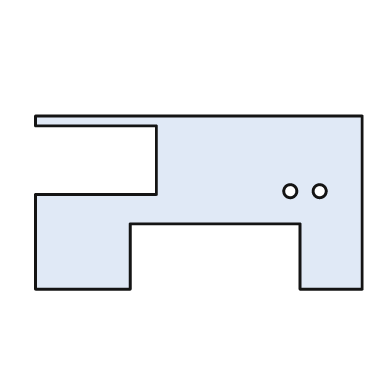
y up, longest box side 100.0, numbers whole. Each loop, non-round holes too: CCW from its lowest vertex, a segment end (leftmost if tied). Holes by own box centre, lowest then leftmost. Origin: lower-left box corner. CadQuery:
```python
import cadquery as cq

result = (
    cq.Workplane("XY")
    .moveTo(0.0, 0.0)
    .lineTo(29.0, 0.0)
    .lineTo(29.0, 20.0)
    .lineTo(81.0, 20.0)
    .lineTo(81.0, 0.0)
    .lineTo(100.0, 0.0)
    .lineTo(100.0, 53.0)
    .lineTo(0.0, 53.0)
    .lineTo(0.0, 50.0)
    .lineTo(37.0, 50.0)
    .lineTo(37.0, 29.0)
    .lineTo(0.0, 29.0)
    .close()
    .moveTo(78.0, 30.0)
    .circle(2.0)
    .moveTo(87.0, 30.0)
    .circle(2.0)
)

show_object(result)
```